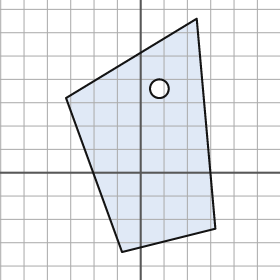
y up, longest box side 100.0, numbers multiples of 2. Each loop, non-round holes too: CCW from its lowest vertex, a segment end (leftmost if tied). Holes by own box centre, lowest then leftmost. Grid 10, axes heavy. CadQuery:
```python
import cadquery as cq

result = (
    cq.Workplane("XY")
    .moveTo(-8.0, -34.0)
    .lineTo(32.0, -24.0)
    .lineTo(24.0, 66.0)
    .lineTo(-32.0, 32.0)
    .close()
    .moveTo(8.0, 36.0)
    .circle(4.0)
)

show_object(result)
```